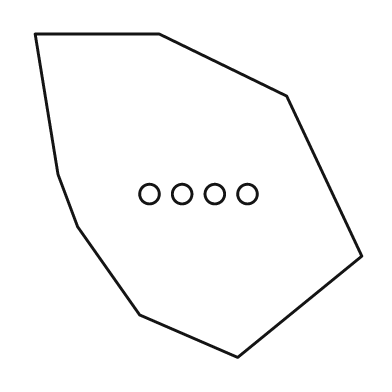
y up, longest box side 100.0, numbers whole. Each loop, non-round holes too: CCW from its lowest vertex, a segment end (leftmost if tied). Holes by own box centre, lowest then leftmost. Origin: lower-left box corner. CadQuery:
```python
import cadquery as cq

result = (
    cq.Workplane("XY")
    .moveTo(62.0, 0.0)
    .lineTo(100.0, 31.0)
    .lineTo(77.0, 80.0)
    .lineTo(38.0, 99.0)
    .lineTo(0.0, 99.0)
    .lineTo(7.0, 56.0)
    .lineTo(13.0, 40.0)
    .lineTo(32.0, 13.0)
    .close()
    .moveTo(35.0, 50.0)
    .circle(3.0)
    .moveTo(45.0, 50.0)
    .circle(3.0)
    .moveTo(55.0, 50.0)
    .circle(3.0)
    .moveTo(65.0, 50.0)
    .circle(3.0)
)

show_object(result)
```